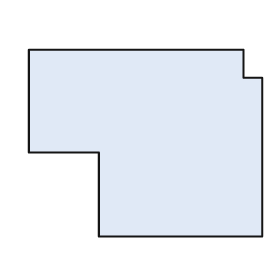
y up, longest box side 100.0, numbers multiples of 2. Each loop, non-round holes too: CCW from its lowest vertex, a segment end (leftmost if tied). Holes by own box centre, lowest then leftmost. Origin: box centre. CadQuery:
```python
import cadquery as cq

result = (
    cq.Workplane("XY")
    .moveTo(-20.0, -40.0)
    .lineTo(50.0, -40.0)
    .lineTo(50.0, 28.0)
    .lineTo(42.0, 28.0)
    .lineTo(42.0, 40.0)
    .lineTo(-50.0, 40.0)
    .lineTo(-50.0, -4.0)
    .lineTo(-20.0, -4.0)
    .close()
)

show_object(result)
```